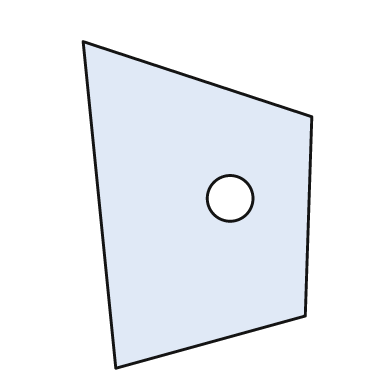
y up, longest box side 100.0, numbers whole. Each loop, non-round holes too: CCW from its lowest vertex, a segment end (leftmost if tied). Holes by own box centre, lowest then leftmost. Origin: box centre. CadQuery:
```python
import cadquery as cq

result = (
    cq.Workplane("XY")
    .moveTo(-25.0, -50.0)
    .lineTo(33.0, -34.0)
    .lineTo(35.0, 27.0)
    .lineTo(-35.0, 50.0)
    .close()
    .moveTo(10.0, 2.0)
    .circle(7.0)
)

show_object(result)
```